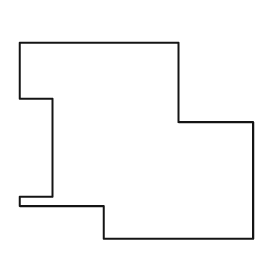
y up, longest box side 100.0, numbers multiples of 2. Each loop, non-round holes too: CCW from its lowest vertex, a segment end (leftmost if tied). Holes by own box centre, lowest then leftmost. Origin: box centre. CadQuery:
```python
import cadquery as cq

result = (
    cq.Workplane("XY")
    .moveTo(-14.0, -42.0)
    .lineTo(50.0, -42.0)
    .lineTo(50.0, 8.0)
    .lineTo(18.0, 8.0)
    .lineTo(18.0, 42.0)
    .lineTo(-50.0, 42.0)
    .lineTo(-50.0, 18.0)
    .lineTo(-36.0, 18.0)
    .lineTo(-36.0, -24.0)
    .lineTo(-50.0, -24.0)
    .lineTo(-50.0, -28.0)
    .lineTo(-14.0, -28.0)
    .close()
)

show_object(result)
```